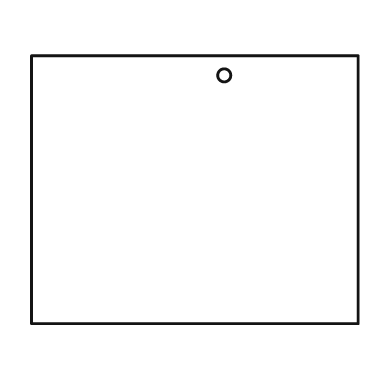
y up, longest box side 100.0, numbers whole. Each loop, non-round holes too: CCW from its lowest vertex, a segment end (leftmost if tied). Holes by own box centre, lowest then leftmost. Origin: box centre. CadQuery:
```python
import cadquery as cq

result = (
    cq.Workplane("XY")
    .moveTo(-50.0, -41.0)
    .lineTo(50.0, -41.0)
    .lineTo(50.0, 41.0)
    .lineTo(-50.0, 41.0)
    .close()
    .moveTo(9.0, 35.0)
    .circle(2.0)
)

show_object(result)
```